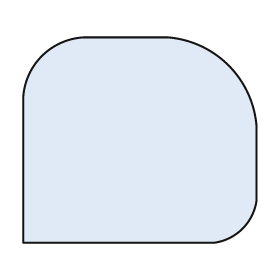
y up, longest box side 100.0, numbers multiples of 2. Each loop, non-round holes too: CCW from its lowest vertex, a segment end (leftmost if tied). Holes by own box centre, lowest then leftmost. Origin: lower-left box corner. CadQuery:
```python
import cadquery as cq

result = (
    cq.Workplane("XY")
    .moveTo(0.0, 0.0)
    .lineTo(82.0, 0.0)
    .threePointArc((94.0, 6.0), (100.0, 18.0))
    .lineTo(100.0, 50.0)
    .threePointArc((88.0, 76.0), (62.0, 88.0))
    .lineTo(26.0, 88.0)
    .threePointArc((8.0, 80.0), (0.0, 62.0))
    .close()
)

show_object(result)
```